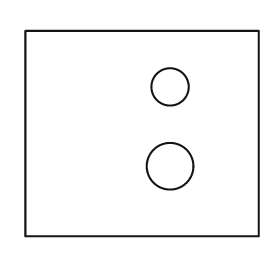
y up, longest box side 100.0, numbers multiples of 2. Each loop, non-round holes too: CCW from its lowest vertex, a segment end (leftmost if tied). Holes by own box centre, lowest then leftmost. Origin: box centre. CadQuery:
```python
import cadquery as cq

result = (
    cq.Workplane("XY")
    .moveTo(-50.0, -44.0)
    .lineTo(50.0, -44.0)
    .lineTo(50.0, 44.0)
    .lineTo(-50.0, 44.0)
    .close()
    .moveTo(12.0, -14.0)
    .circle(10.0)
    .moveTo(12.0, 20.0)
    .circle(8.0)
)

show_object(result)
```